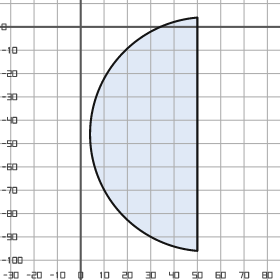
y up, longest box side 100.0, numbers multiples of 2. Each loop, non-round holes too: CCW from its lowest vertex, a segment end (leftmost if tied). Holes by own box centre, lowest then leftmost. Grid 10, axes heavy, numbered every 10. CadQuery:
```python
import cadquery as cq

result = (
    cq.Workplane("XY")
    .moveTo(50.0, -96.0)
    .lineTo(50.0, 4.0)
    .threePointArc((4.0, -46.0), (50.0, -96.0))
    .close()
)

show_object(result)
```